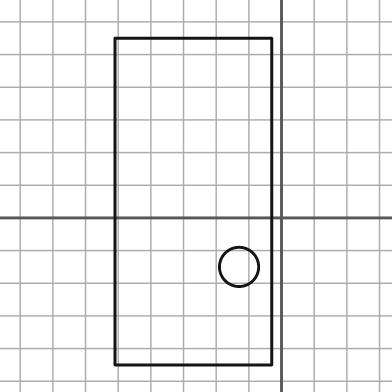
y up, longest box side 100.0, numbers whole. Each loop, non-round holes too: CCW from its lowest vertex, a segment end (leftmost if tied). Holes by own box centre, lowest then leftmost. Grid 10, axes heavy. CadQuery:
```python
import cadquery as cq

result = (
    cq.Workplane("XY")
    .moveTo(-51.0, -45.0)
    .lineTo(-3.0, -45.0)
    .lineTo(-3.0, 55.0)
    .lineTo(-51.0, 55.0)
    .close()
    .moveTo(-13.0, -15.0)
    .circle(6.0)
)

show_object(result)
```